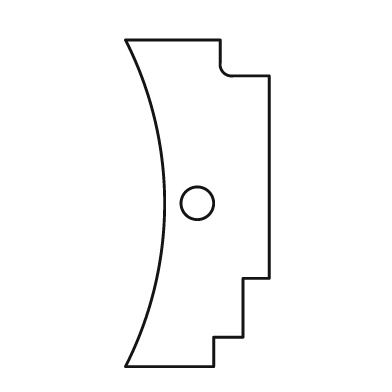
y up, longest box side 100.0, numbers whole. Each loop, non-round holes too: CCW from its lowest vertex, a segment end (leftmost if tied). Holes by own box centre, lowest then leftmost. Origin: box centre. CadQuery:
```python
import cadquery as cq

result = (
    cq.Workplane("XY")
    .moveTo(-22.0, -50.0)
    .lineTo(5.0, -50.0)
    .lineTo(5.0, -41.0)
    .lineTo(14.0, -41.0)
    .lineTo(14.0, -23.0)
    .lineTo(22.0, -23.0)
    .lineTo(22.0, 39.0)
    .lineTo(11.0, 39.0)
    .threePointArc((8.0, 40.0), (7.0, 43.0))
    .lineTo(7.0, 50.0)
    .lineTo(-22.0, 50.0)
    .threePointArc((-10.0, 0.0), (-22.0, -50.0))
    .close()
    .moveTo(0.0, 0.0)
    .circle(5.0)
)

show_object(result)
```